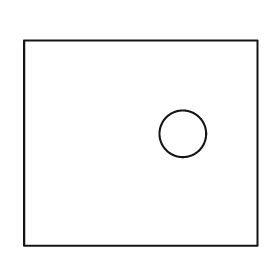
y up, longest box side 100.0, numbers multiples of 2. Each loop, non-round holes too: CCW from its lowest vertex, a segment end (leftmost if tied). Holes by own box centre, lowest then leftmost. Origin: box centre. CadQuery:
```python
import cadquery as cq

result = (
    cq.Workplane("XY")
    .moveTo(-50.0, -44.0)
    .lineTo(50.0, -44.0)
    .lineTo(50.0, 44.0)
    .lineTo(-50.0, 44.0)
    .close()
    .moveTo(18.0, 4.0)
    .circle(10.0)
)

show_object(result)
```